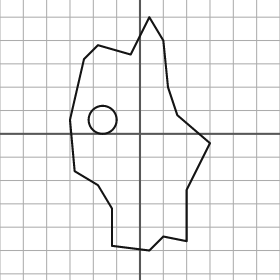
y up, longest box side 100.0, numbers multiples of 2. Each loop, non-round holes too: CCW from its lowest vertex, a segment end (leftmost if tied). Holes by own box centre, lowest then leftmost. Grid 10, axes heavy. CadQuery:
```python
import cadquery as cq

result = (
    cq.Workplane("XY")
    .moveTo(4.0, -50.0)
    .lineTo(10.0, -44.0)
    .lineTo(20.0, -46.0)
    .lineTo(20.0, -24.0)
    .lineTo(30.0, -4.0)
    .lineTo(16.0, 8.0)
    .lineTo(12.0, 20.0)
    .lineTo(10.0, 40.0)
    .lineTo(4.0, 50.0)
    .lineTo(-4.0, 34.0)
    .lineTo(-18.0, 38.0)
    .lineTo(-24.0, 32.0)
    .lineTo(-30.0, 6.0)
    .lineTo(-28.0, -16.0)
    .lineTo(-18.0, -22.0)
    .lineTo(-12.0, -32.0)
    .lineTo(-12.0, -48.0)
    .close()
    .moveTo(-16.0, 6.0)
    .circle(6.0)
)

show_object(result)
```